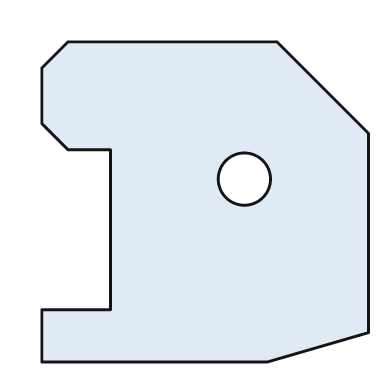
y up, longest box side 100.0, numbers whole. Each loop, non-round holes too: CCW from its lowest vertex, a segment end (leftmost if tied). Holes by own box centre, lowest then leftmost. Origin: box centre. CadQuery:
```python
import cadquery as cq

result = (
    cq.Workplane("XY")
    .moveTo(-50.0, -49.0)
    .lineTo(19.0, -49.0)
    .lineTo(50.0, -40.0)
    .lineTo(50.0, 21.0)
    .lineTo(22.0, 49.0)
    .lineTo(-42.0, 49.0)
    .lineTo(-50.0, 41.0)
    .lineTo(-50.0, 24.0)
    .lineTo(-42.0, 16.0)
    .lineTo(-29.0, 16.0)
    .lineTo(-29.0, -33.0)
    .lineTo(-50.0, -33.0)
    .close()
    .moveTo(12.0, 7.0)
    .circle(8.0)
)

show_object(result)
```